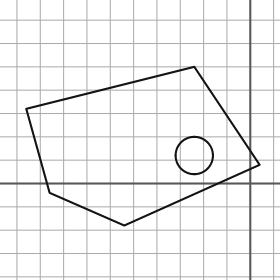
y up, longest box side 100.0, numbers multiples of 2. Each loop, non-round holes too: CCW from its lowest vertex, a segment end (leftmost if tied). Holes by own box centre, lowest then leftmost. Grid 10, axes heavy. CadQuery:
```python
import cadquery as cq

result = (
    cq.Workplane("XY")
    .moveTo(-54.0, -18.0)
    .lineTo(4.0, 8.0)
    .lineTo(-24.0, 50.0)
    .lineTo(-96.0, 32.0)
    .lineTo(-86.0, -4.0)
    .close()
    .moveTo(-24.0, 12.0)
    .circle(8.0)
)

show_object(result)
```